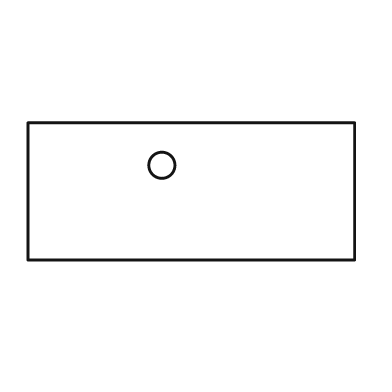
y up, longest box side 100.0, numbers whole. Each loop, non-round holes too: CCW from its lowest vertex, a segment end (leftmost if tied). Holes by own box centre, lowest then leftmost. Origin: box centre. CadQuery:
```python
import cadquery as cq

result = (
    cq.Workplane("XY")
    .moveTo(-50.0, -21.0)
    .lineTo(50.0, -21.0)
    .lineTo(50.0, 21.0)
    .lineTo(-50.0, 21.0)
    .close()
    .moveTo(-9.0, 8.0)
    .circle(4.0)
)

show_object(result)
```